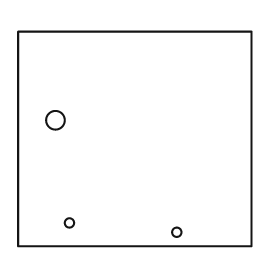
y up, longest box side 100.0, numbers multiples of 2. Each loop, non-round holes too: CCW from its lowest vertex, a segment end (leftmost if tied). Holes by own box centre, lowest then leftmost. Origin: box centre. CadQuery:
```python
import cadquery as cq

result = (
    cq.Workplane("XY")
    .moveTo(-50.0, -46.0)
    .lineTo(50.0, -46.0)
    .lineTo(50.0, 46.0)
    .lineTo(-50.0, 46.0)
    .close()
    .moveTo(18.0, -40.0)
    .circle(2.0)
    .moveTo(-28.0, -36.0)
    .circle(2.0)
    .moveTo(-34.0, 8.0)
    .circle(4.0)
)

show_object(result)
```